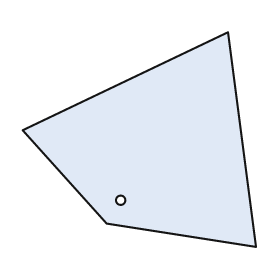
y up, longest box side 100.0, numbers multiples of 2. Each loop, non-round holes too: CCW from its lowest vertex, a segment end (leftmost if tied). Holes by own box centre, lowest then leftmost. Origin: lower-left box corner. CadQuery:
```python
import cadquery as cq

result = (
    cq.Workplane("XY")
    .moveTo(100.0, 0.0)
    .lineTo(88.0, 92.0)
    .lineTo(0.0, 50.0)
    .lineTo(36.0, 10.0)
    .close()
    .moveTo(42.0, 20.0)
    .circle(2.0)
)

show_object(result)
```